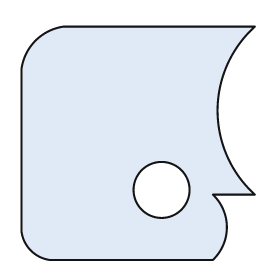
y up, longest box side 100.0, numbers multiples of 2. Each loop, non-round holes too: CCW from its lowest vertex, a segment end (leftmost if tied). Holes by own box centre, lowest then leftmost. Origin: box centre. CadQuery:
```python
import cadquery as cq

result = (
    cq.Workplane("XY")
    .moveTo(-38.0, -50.0)
    .lineTo(32.0, -50.0)
    .threePointArc((38.0, -36.0), (32.0, -22.0))
    .lineTo(50.0, -22.0)
    .threePointArc((34.0, 14.0), (50.0, 50.0))
    .lineTo(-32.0, 50.0)
    .threePointArc((-44.0, 44.0), (-50.0, 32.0))
    .lineTo(-50.0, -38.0)
    .threePointArc((-46.0, -46.0), (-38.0, -50.0))
    .close()
    .moveTo(10.0, -20.0)
    .circle(12.0)
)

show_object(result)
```